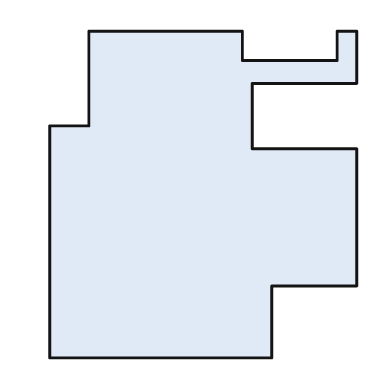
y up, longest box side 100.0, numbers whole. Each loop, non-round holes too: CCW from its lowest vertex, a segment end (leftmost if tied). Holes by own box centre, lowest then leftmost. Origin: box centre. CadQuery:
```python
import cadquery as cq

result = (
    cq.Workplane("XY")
    .moveTo(-47.0, -50.0)
    .lineTo(21.0, -50.0)
    .lineTo(21.0, -28.0)
    .lineTo(47.0, -28.0)
    .lineTo(47.0, 14.0)
    .lineTo(15.0, 14.0)
    .lineTo(15.0, 34.0)
    .lineTo(47.0, 34.0)
    .lineTo(47.0, 50.0)
    .lineTo(41.0, 50.0)
    .lineTo(41.0, 41.0)
    .lineTo(12.0, 41.0)
    .lineTo(12.0, 50.0)
    .lineTo(-35.0, 50.0)
    .lineTo(-35.0, 21.0)
    .lineTo(-47.0, 21.0)
    .close()
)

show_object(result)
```